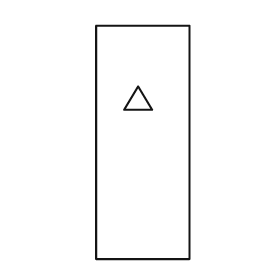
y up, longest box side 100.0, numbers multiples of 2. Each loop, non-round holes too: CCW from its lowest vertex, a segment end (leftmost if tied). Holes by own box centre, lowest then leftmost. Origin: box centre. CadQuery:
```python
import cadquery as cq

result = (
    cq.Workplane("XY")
    .moveTo(-20.0, -50.0)
    .lineTo(20.0, -50.0)
    .lineTo(20.0, 50.0)
    .lineTo(-20.0, 50.0)
    .close()
    .moveTo(-8.0, 14.0)
    .lineTo(4.0, 14.0)
    .lineTo(-2.0, 24.0)
    .close()
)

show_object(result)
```